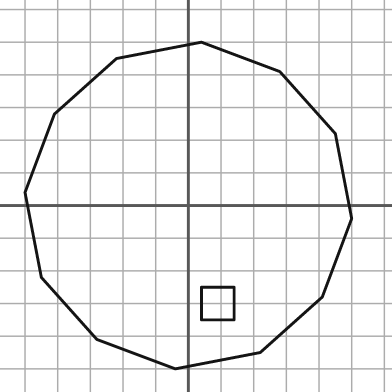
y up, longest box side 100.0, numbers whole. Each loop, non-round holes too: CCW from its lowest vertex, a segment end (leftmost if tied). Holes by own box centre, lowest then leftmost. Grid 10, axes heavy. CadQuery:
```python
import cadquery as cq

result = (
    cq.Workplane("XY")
    .moveTo(-4.0, -50.0)
    .lineTo(22.0, -45.0)
    .lineTo(41.0, -28.0)
    .lineTo(50.0, -4.0)
    .lineTo(45.0, 22.0)
    .lineTo(28.0, 41.0)
    .lineTo(4.0, 50.0)
    .lineTo(-22.0, 45.0)
    .lineTo(-41.0, 28.0)
    .lineTo(-50.0, 4.0)
    .lineTo(-45.0, -22.0)
    .lineTo(-28.0, -41.0)
    .close()
    .moveTo(4.0, -35.0)
    .lineTo(14.0, -35.0)
    .lineTo(14.0, -25.0)
    .lineTo(4.0, -25.0)
    .close()
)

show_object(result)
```